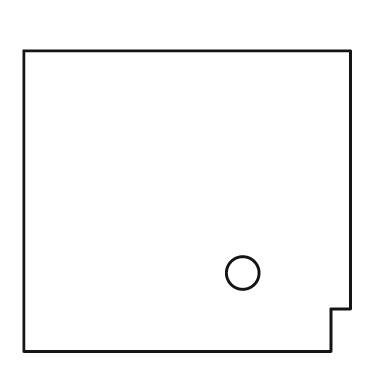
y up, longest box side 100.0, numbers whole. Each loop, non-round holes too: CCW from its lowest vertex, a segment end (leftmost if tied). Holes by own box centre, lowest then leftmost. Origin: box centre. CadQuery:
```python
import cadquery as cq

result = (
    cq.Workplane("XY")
    .moveTo(-50.0, -46.0)
    .lineTo(44.0, -46.0)
    .lineTo(44.0, -33.0)
    .lineTo(50.0, -33.0)
    .lineTo(50.0, 46.0)
    .lineTo(-50.0, 46.0)
    .close()
    .moveTo(17.0, -22.0)
    .circle(5.0)
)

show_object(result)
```